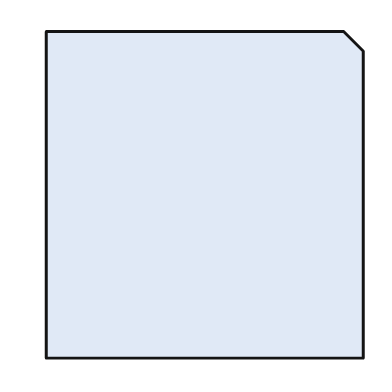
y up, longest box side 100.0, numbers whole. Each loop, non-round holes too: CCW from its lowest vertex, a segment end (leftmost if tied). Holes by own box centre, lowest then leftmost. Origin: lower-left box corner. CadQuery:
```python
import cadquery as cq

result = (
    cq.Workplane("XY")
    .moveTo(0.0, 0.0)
    .lineTo(97.0, 0.0)
    .lineTo(97.0, 94.0)
    .lineTo(91.0, 100.0)
    .lineTo(0.0, 100.0)
    .close()
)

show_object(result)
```